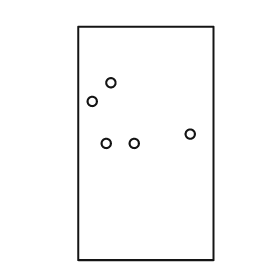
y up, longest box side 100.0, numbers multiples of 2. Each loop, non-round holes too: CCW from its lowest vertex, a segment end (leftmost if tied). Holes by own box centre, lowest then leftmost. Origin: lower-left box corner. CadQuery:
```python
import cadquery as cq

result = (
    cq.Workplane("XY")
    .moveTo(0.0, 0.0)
    .lineTo(58.0, 0.0)
    .lineTo(58.0, 100.0)
    .lineTo(0.0, 100.0)
    .close()
    .moveTo(12.0, 50.0)
    .circle(2.0)
    .moveTo(24.0, 50.0)
    .circle(2.0)
    .moveTo(48.0, 54.0)
    .circle(2.0)
    .moveTo(6.0, 68.0)
    .circle(2.0)
    .moveTo(14.0, 76.0)
    .circle(2.0)
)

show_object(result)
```